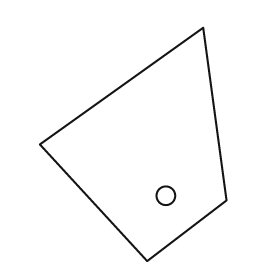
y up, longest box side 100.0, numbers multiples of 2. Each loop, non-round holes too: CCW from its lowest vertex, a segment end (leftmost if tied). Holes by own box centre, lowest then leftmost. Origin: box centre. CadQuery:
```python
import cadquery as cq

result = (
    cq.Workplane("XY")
    .moveTo(6.0, -50.0)
    .lineTo(40.0, -24.0)
    .lineTo(30.0, 50.0)
    .lineTo(-40.0, 0.0)
    .close()
    .moveTo(14.0, -22.0)
    .circle(4.0)
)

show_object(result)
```